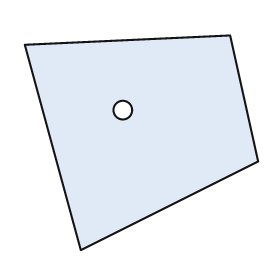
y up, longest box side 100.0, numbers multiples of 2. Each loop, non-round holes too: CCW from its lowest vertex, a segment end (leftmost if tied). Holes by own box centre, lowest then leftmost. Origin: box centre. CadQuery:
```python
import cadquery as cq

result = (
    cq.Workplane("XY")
    .moveTo(-26.0, -46.0)
    .lineTo(50.0, -8.0)
    .lineTo(38.0, 46.0)
    .lineTo(-50.0, 42.0)
    .close()
    .moveTo(-8.0, 14.0)
    .circle(4.0)
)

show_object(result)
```